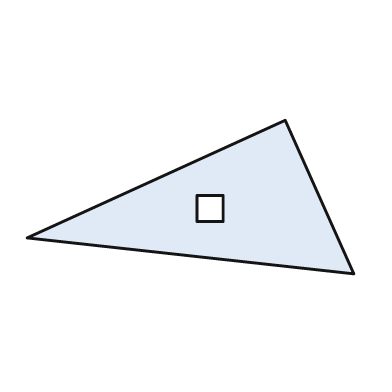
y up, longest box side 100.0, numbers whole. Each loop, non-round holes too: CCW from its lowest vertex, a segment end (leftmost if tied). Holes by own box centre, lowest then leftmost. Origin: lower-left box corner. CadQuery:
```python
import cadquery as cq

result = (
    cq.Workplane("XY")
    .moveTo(100.0, 0.0)
    .lineTo(79.0, 47.0)
    .lineTo(0.0, 11.0)
    .close()
    .moveTo(52.0, 16.0)
    .lineTo(60.0, 16.0)
    .lineTo(60.0, 24.0)
    .lineTo(52.0, 24.0)
    .close()
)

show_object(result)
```